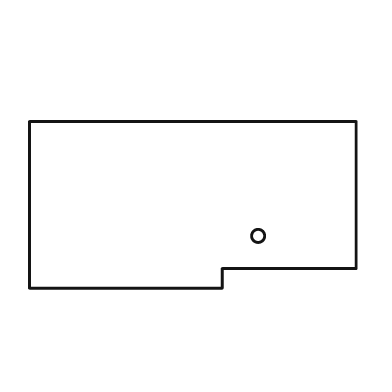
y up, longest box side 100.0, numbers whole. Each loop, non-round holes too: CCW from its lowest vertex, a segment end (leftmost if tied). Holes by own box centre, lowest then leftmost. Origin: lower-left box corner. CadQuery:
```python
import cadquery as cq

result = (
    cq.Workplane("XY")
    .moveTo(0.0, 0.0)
    .lineTo(59.0, 0.0)
    .lineTo(59.0, 6.0)
    .lineTo(100.0, 6.0)
    .lineTo(100.0, 51.0)
    .lineTo(0.0, 51.0)
    .close()
    .moveTo(70.0, 16.0)
    .circle(2.0)
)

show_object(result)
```